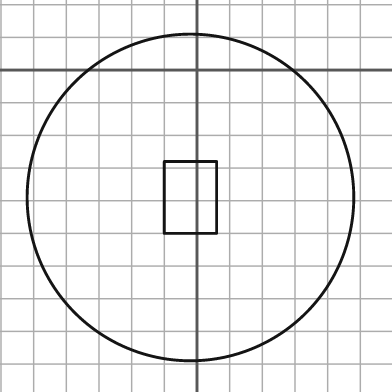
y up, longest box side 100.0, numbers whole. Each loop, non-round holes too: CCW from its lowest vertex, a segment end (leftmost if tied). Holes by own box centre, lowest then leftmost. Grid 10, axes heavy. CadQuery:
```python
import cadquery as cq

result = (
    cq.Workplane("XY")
    .moveTo(-2.0, -39.0)
    .circle(50.0)
    .moveTo(-10.0, -50.0)
    .lineTo(6.0, -50.0)
    .lineTo(6.0, -28.0)
    .lineTo(-10.0, -28.0)
    .close()
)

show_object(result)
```